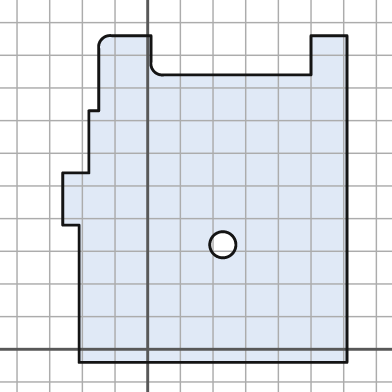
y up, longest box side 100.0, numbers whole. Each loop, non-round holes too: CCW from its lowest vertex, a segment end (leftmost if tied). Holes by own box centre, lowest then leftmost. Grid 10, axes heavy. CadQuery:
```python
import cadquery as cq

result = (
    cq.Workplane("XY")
    .moveTo(-21.0, -4.0)
    .lineTo(61.0, -4.0)
    .lineTo(61.0, 96.0)
    .lineTo(50.0, 96.0)
    .lineTo(50.0, 84.0)
    .lineTo(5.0, 84.0)
    .threePointArc((2.0, 85.0), (1.0, 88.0))
    .lineTo(1.0, 96.0)
    .lineTo(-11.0, 96.0)
    .threePointArc((-14.0, 95.0), (-15.0, 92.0))
    .lineTo(-15.0, 73.0)
    .lineTo(-18.0, 73.0)
    .lineTo(-18.0, 54.0)
    .lineTo(-26.0, 54.0)
    .lineTo(-26.0, 38.0)
    .lineTo(-21.0, 38.0)
    .close()
    .moveTo(23.0, 32.0)
    .circle(4.0)
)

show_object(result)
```